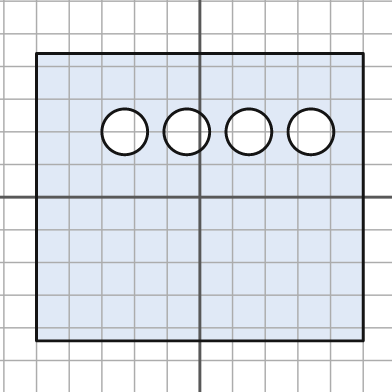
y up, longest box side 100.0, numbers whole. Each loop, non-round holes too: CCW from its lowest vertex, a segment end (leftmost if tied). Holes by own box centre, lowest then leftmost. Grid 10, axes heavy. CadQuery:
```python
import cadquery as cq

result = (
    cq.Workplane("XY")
    .moveTo(-50.0, -44.0)
    .lineTo(50.0, -44.0)
    .lineTo(50.0, 44.0)
    .lineTo(-50.0, 44.0)
    .close()
    .moveTo(-23.0, 20.0)
    .circle(7.0)
    .moveTo(-4.0, 20.0)
    .circle(7.0)
    .moveTo(15.0, 20.0)
    .circle(7.0)
    .moveTo(34.0, 20.0)
    .circle(7.0)
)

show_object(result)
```